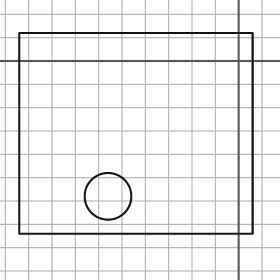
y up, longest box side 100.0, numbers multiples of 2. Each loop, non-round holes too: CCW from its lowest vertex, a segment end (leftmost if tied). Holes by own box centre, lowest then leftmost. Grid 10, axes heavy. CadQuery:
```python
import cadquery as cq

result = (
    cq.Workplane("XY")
    .moveTo(-94.0, -74.0)
    .lineTo(6.0, -74.0)
    .lineTo(6.0, 12.0)
    .lineTo(-94.0, 12.0)
    .close()
    .moveTo(-56.0, -58.0)
    .circle(10.0)
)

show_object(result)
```